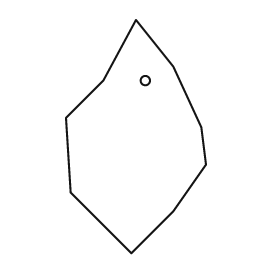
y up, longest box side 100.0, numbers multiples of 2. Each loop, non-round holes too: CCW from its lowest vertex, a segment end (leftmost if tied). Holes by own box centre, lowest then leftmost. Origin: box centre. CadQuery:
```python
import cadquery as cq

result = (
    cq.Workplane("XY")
    .moveTo(-2.0, -50.0)
    .lineTo(16.0, -32.0)
    .lineTo(30.0, -12.0)
    .lineTo(28.0, 4.0)
    .lineTo(16.0, 30.0)
    .lineTo(0.0, 50.0)
    .lineTo(-14.0, 24.0)
    .lineTo(-30.0, 8.0)
    .lineTo(-28.0, -24.0)
    .close()
    .moveTo(4.0, 24.0)
    .circle(2.0)
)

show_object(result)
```